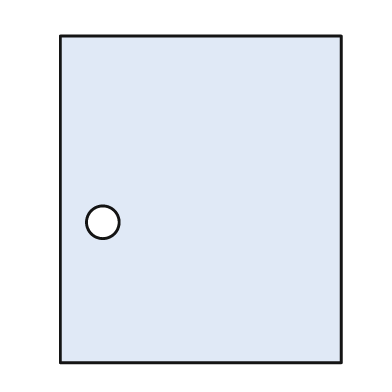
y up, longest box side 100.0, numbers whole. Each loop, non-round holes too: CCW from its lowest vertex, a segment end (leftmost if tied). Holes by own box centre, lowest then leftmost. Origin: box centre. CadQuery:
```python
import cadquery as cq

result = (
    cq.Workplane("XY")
    .moveTo(-43.0, -50.0)
    .lineTo(43.0, -50.0)
    .lineTo(43.0, 50.0)
    .lineTo(-43.0, 50.0)
    .close()
    .moveTo(-30.0, -7.0)
    .circle(5.0)
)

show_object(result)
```